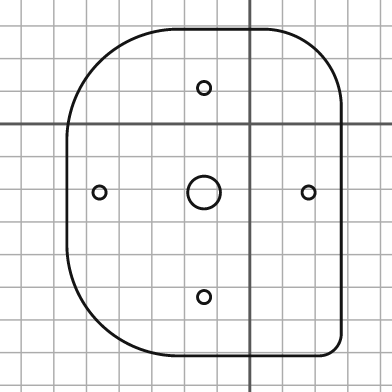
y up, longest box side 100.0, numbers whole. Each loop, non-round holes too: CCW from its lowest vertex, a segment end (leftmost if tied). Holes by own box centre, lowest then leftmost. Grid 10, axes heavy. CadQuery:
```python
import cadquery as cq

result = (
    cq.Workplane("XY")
    .moveTo(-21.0, -71.0)
    .lineTo(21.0, -71.0)
    .threePointArc((26.0, -69.0), (28.0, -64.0))
    .lineTo(28.0, 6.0)
    .threePointArc((21.0, 22.0), (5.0, 29.0))
    .lineTo(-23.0, 29.0)
    .threePointArc((-46.0, 19.0), (-56.0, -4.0))
    .lineTo(-56.0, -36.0)
    .threePointArc((-46.0, -61.0), (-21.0, -71.0))
    .close()
    .moveTo(-14.0, -53.0)
    .circle(2.0)
    .moveTo(-46.0, -21.0)
    .circle(2.0)
    .moveTo(-14.0, -21.0)
    .circle(5.0)
    .moveTo(18.0, -21.0)
    .circle(2.0)
    .moveTo(-14.0, 11.0)
    .circle(2.0)
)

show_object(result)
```